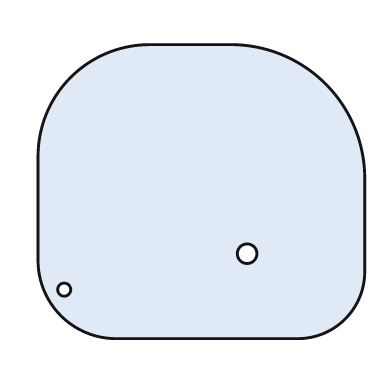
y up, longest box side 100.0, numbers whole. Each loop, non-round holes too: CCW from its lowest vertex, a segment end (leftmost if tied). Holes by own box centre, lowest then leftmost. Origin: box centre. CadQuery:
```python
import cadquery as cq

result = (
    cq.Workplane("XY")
    .moveTo(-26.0, -45.0)
    .lineTo(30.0, -45.0)
    .threePointArc((44.0, -39.0), (50.0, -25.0))
    .lineTo(50.0, 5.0)
    .threePointArc((38.0, 33.0), (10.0, 45.0))
    .lineTo(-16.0, 45.0)
    .threePointArc((-40.0, 35.0), (-50.0, 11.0))
    .lineTo(-50.0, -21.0)
    .threePointArc((-43.0, -38.0), (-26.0, -45.0))
    .close()
    .moveTo(-42.0, -30.0)
    .circle(2.0)
    .moveTo(14.0, -19.0)
    .circle(3.0)
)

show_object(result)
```